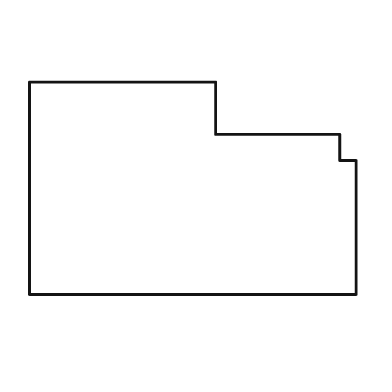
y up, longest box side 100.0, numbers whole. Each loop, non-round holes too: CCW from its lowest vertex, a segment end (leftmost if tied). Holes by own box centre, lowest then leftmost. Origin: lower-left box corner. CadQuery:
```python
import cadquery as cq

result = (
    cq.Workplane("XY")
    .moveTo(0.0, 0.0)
    .lineTo(100.0, 0.0)
    .lineTo(100.0, 41.0)
    .lineTo(95.0, 41.0)
    .lineTo(95.0, 49.0)
    .lineTo(57.0, 49.0)
    .lineTo(57.0, 65.0)
    .lineTo(0.0, 65.0)
    .close()
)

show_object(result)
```